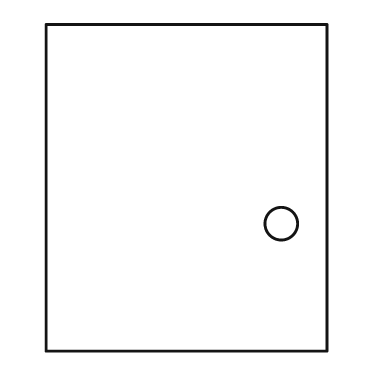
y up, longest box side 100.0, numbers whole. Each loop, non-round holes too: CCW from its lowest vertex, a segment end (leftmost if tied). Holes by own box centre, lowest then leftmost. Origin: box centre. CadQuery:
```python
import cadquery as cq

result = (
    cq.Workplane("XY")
    .moveTo(-43.0, -50.0)
    .lineTo(43.0, -50.0)
    .lineTo(43.0, 50.0)
    .lineTo(-43.0, 50.0)
    .close()
    .moveTo(29.0, -11.0)
    .circle(5.0)
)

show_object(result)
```